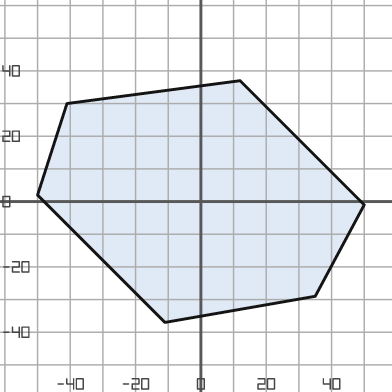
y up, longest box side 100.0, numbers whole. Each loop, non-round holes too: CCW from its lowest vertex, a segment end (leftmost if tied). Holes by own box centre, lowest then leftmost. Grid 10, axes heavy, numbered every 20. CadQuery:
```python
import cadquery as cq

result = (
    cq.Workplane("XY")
    .moveTo(-11.0, -37.0)
    .lineTo(35.0, -29.0)
    .lineTo(50.0, -1.0)
    .lineTo(12.0, 37.0)
    .lineTo(-41.0, 30.0)
    .lineTo(-50.0, 2.0)
    .close()
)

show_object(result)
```